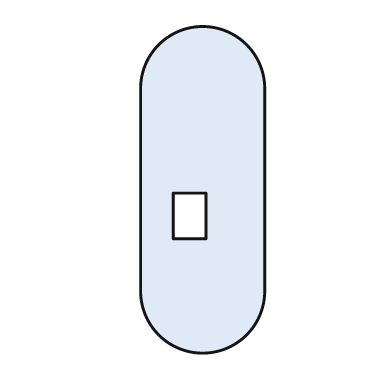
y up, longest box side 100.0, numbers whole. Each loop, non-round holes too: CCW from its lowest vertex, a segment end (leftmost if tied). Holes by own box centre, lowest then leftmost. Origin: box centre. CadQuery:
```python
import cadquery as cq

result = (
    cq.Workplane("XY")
    .moveTo(-19.0, -31.0)
    .threePointArc((0.0, -50.0), (19.0, -31.0))
    .lineTo(19.0, 31.0)
    .threePointArc((0.0, 50.0), (-19.0, 31.0))
    .close()
    .moveTo(-9.0, -15.0)
    .lineTo(1.0, -15.0)
    .lineTo(1.0, -1.0)
    .lineTo(-9.0, -1.0)
    .close()
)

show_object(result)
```